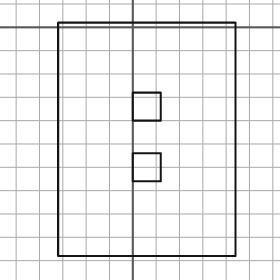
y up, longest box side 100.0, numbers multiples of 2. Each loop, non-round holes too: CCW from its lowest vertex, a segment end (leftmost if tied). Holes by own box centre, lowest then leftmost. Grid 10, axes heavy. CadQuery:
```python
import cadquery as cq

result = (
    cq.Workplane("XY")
    .moveTo(-32.0, -98.0)
    .lineTo(44.0, -98.0)
    .lineTo(44.0, 2.0)
    .lineTo(-32.0, 2.0)
    .close()
    .moveTo(0.0, -66.0)
    .lineTo(12.0, -66.0)
    .lineTo(12.0, -54.0)
    .lineTo(0.0, -54.0)
    .close()
    .moveTo(0.0, -40.0)
    .lineTo(12.0, -40.0)
    .lineTo(12.0, -28.0)
    .lineTo(0.0, -28.0)
    .close()
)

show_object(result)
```